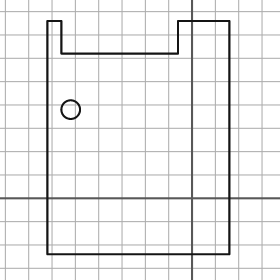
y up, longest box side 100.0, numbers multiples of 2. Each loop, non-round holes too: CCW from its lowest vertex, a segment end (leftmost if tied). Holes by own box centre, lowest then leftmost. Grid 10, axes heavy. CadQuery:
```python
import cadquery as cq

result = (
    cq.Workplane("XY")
    .moveTo(-62.0, -24.0)
    .lineTo(16.0, -24.0)
    .lineTo(16.0, 76.0)
    .lineTo(-6.0, 76.0)
    .lineTo(-6.0, 62.0)
    .lineTo(-56.0, 62.0)
    .lineTo(-56.0, 76.0)
    .lineTo(-62.0, 76.0)
    .close()
    .moveTo(-52.0, 38.0)
    .circle(4.0)
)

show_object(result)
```